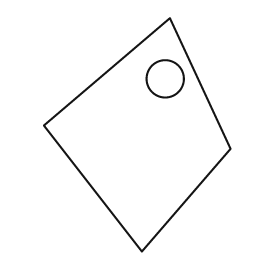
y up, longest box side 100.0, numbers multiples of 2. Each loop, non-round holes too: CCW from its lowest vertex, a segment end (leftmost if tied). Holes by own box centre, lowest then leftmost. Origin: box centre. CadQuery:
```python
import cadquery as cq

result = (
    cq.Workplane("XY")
    .moveTo(2.0, -50.0)
    .lineTo(40.0, -6.0)
    .lineTo(14.0, 50.0)
    .lineTo(-40.0, 4.0)
    .close()
    .moveTo(12.0, 24.0)
    .circle(8.0)
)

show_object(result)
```